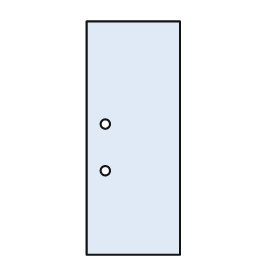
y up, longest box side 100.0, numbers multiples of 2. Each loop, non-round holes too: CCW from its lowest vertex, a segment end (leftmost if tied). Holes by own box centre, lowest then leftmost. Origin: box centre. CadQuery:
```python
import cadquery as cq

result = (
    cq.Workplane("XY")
    .moveTo(-20.0, -50.0)
    .lineTo(20.0, -50.0)
    .lineTo(20.0, 50.0)
    .lineTo(-20.0, 50.0)
    .close()
    .moveTo(-12.0, -14.0)
    .circle(2.0)
    .moveTo(-12.0, 6.0)
    .circle(2.0)
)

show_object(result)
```